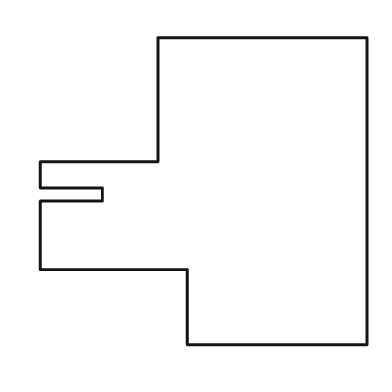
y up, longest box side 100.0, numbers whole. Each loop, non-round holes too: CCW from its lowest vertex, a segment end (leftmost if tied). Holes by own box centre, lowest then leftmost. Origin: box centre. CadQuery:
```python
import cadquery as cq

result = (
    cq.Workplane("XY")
    .moveTo(-5.0, -47.0)
    .lineTo(50.0, -47.0)
    .lineTo(50.0, 47.0)
    .lineTo(-14.0, 47.0)
    .lineTo(-14.0, 9.0)
    .lineTo(-50.0, 9.0)
    .lineTo(-50.0, 1.0)
    .lineTo(-31.0, 1.0)
    .lineTo(-31.0, -3.0)
    .lineTo(-50.0, -3.0)
    .lineTo(-50.0, -24.0)
    .lineTo(-5.0, -24.0)
    .close()
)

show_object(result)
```